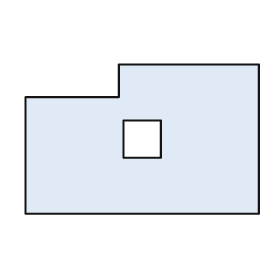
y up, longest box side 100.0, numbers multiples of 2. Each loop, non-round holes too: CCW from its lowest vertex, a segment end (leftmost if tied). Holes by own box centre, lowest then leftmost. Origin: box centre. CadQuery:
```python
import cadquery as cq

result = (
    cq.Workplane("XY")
    .moveTo(-50.0, -32.0)
    .lineTo(50.0, -32.0)
    .lineTo(50.0, 32.0)
    .lineTo(-10.0, 32.0)
    .lineTo(-10.0, 18.0)
    .lineTo(-50.0, 18.0)
    .close()
    .moveTo(-8.0, -8.0)
    .lineTo(8.0, -8.0)
    .lineTo(8.0, 8.0)
    .lineTo(-8.0, 8.0)
    .close()
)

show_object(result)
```